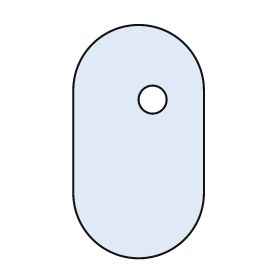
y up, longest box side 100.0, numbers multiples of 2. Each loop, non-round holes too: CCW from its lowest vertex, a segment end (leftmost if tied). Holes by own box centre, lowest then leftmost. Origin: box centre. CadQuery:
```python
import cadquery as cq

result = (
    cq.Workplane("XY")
    .moveTo(-28.0, -22.0)
    .threePointArc((0.0, -50.0), (28.0, -22.0))
    .lineTo(28.0, 22.0)
    .threePointArc((0.0, 50.0), (-28.0, 22.0))
    .close()
    .moveTo(6.0, 18.0)
    .circle(6.0)
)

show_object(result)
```